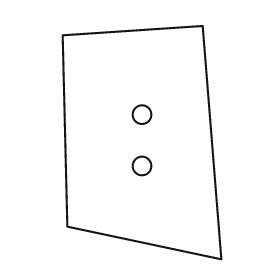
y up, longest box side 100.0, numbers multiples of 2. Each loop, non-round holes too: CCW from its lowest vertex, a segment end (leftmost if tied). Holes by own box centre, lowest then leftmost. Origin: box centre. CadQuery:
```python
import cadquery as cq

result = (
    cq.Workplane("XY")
    .moveTo(34.0, -50.0)
    .lineTo(26.0, 50.0)
    .lineTo(-34.0, 46.0)
    .lineTo(-32.0, -36.0)
    .close()
    .moveTo(0.0, -10.0)
    .circle(4.0)
    .moveTo(0.0, 12.0)
    .circle(4.0)
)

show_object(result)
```